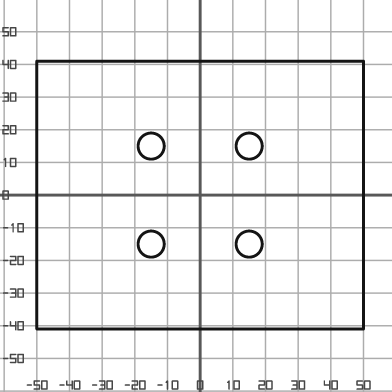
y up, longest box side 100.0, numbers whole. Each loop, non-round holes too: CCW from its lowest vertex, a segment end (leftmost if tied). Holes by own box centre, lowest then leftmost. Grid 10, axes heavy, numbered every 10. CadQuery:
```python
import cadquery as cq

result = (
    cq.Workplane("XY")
    .moveTo(-50.0, -41.0)
    .lineTo(50.0, -41.0)
    .lineTo(50.0, 41.0)
    .lineTo(-50.0, 41.0)
    .close()
    .moveTo(-15.0, -15.0)
    .circle(4.0)
    .moveTo(15.0, -15.0)
    .circle(4.0)
    .moveTo(-15.0, 15.0)
    .circle(4.0)
    .moveTo(15.0, 15.0)
    .circle(4.0)
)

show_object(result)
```